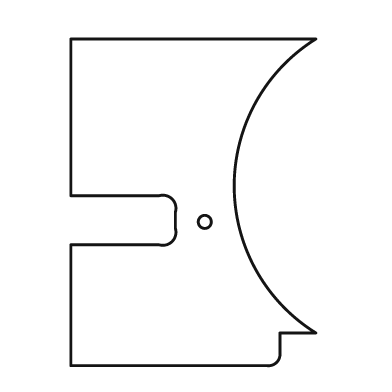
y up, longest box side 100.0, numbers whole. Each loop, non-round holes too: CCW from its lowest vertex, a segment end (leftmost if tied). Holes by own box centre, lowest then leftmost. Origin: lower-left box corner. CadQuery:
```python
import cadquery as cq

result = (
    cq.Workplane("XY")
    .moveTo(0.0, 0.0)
    .lineTo(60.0, 0.0)
    .threePointArc((63.0, 1.0), (64.0, 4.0))
    .lineTo(64.0, 10.0)
    .lineTo(75.0, 10.0)
    .threePointArc((50.0, 55.0), (75.0, 100.0))
    .lineTo(0.0, 100.0)
    .lineTo(0.0, 52.0)
    .lineTo(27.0, 52.0)
    .threePointArc((31.0, 51.0), (32.0, 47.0))
    .lineTo(32.0, 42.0)
    .threePointArc((31.0, 38.0), (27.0, 37.0))
    .lineTo(0.0, 37.0)
    .close()
    .moveTo(41.0, 44.0)
    .circle(2.0)
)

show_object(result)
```